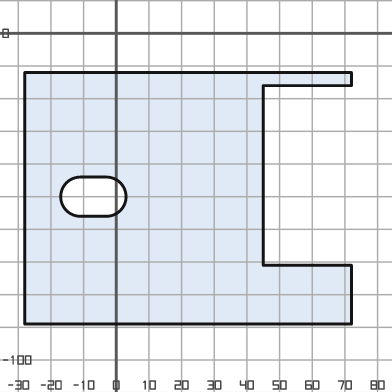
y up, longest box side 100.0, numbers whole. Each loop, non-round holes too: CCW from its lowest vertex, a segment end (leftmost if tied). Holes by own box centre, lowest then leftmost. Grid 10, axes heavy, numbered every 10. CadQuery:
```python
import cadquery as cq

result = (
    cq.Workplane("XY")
    .moveTo(-28.0, -89.0)
    .lineTo(72.0, -89.0)
    .lineTo(72.0, -71.0)
    .lineTo(45.0, -71.0)
    .lineTo(45.0, -16.0)
    .lineTo(72.0, -16.0)
    .lineTo(72.0, -12.0)
    .lineTo(-28.0, -12.0)
    .close()
    .moveTo(-11.0, -56.0)
    .lineTo(-3.0, -56.0)
    .threePointArc((3.0, -50.0), (-3.0, -44.0))
    .lineTo(-11.0, -44.0)
    .threePointArc((-17.0, -50.0), (-11.0, -56.0))
    .close()
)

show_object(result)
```